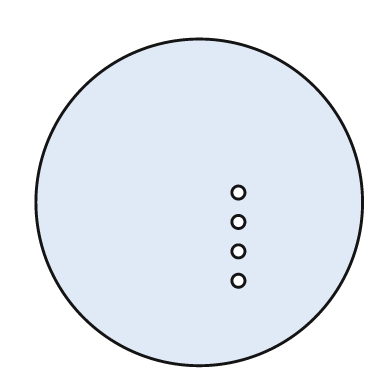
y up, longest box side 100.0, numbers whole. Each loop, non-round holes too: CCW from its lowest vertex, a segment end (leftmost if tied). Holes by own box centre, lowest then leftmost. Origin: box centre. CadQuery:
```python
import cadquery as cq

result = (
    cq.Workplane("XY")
    .moveTo(0.0, 0.0)
    .circle(50.0)
    .moveTo(12.0, -24.0)
    .circle(2.0)
    .moveTo(12.0, -15.0)
    .circle(2.0)
    .moveTo(12.0, -6.0)
    .circle(2.0)
    .moveTo(12.0, 3.0)
    .circle(2.0)
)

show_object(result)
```